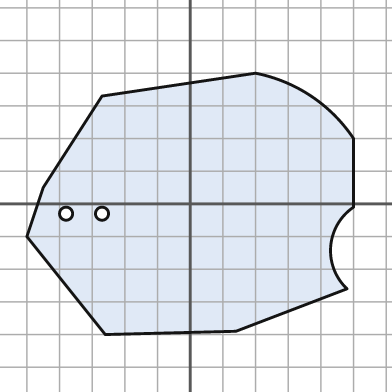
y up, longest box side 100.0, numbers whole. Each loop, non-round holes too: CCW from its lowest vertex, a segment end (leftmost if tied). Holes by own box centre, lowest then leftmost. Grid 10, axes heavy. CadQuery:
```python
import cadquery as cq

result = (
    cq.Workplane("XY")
    .moveTo(-26.0, -40.0)
    .lineTo(14.0, -39.0)
    .lineTo(48.0, -26.0)
    .threePointArc((43.0, -13.0), (50.0, -1.0))
    .lineTo(50.0, 20.0)
    .threePointArc((37.0, 33.0), (20.0, 40.0))
    .lineTo(-27.0, 33.0)
    .lineTo(-45.0, 5.0)
    .lineTo(-50.0, -10.0)
    .close()
    .moveTo(-38.0, -3.0)
    .circle(2.0)
    .moveTo(-27.0, -3.0)
    .circle(2.0)
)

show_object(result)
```